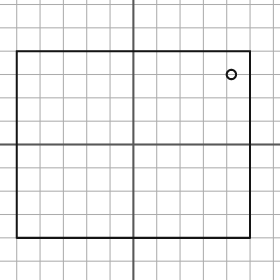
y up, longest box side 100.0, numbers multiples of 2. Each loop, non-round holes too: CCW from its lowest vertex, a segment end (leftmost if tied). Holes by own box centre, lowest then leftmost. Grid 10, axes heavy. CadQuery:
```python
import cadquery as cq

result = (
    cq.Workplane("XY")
    .moveTo(-50.0, -40.0)
    .lineTo(50.0, -40.0)
    .lineTo(50.0, 40.0)
    .lineTo(-50.0, 40.0)
    .close()
    .moveTo(42.0, 30.0)
    .circle(2.0)
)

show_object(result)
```